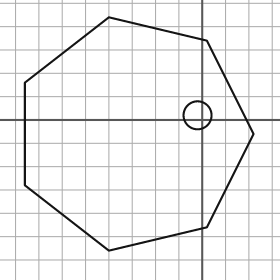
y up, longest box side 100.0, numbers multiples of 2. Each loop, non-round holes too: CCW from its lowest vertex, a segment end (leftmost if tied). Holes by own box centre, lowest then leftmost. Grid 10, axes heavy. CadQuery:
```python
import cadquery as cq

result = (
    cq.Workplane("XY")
    .moveTo(-40.0, -56.0)
    .lineTo(2.0, -46.0)
    .lineTo(22.0, -6.0)
    .lineTo(2.0, 34.0)
    .lineTo(-40.0, 44.0)
    .lineTo(-76.0, 16.0)
    .lineTo(-76.0, -28.0)
    .close()
    .moveTo(-2.0, 2.0)
    .circle(6.0)
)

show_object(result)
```